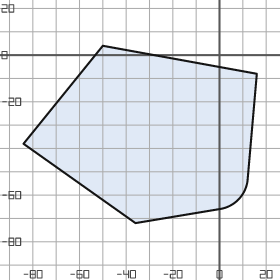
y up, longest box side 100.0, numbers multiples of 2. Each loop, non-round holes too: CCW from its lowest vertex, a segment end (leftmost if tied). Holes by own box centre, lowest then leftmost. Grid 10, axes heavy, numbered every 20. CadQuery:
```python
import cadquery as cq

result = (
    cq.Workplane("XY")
    .moveTo(-36.0, -72.0)
    .lineTo(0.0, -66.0)
    .threePointArc((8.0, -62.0), (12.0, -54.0))
    .lineTo(16.0, -8.0)
    .lineTo(-50.0, 4.0)
    .lineTo(-84.0, -38.0)
    .close()
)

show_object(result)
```